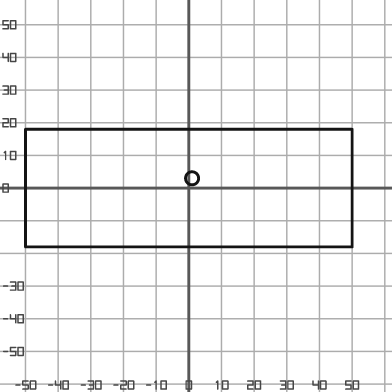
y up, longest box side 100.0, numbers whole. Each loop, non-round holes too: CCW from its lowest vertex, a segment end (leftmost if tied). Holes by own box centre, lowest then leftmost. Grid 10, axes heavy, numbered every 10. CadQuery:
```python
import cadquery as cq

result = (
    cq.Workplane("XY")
    .moveTo(-50.0, -18.0)
    .lineTo(50.0, -18.0)
    .lineTo(50.0, 18.0)
    .lineTo(-50.0, 18.0)
    .close()
    .moveTo(1.0, 3.0)
    .circle(2.0)
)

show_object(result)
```